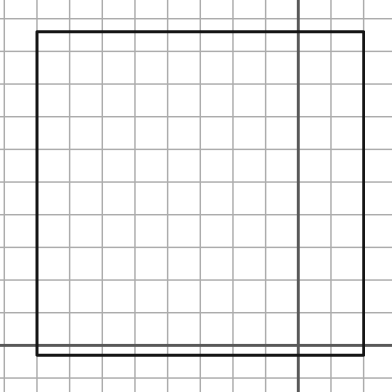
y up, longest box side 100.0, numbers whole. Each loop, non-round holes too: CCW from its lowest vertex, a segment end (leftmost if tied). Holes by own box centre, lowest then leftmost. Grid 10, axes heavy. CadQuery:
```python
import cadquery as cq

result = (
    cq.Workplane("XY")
    .moveTo(-80.0, -3.0)
    .lineTo(20.0, -3.0)
    .lineTo(20.0, 96.0)
    .lineTo(-80.0, 96.0)
    .close()
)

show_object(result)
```